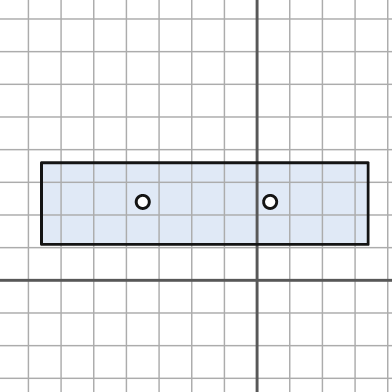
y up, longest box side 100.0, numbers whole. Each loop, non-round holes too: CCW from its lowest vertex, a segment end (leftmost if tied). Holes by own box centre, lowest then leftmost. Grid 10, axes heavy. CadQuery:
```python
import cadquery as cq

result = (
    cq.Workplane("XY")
    .moveTo(-66.0, 11.0)
    .lineTo(34.0, 11.0)
    .lineTo(34.0, 36.0)
    .lineTo(-66.0, 36.0)
    .close()
    .moveTo(-35.0, 24.0)
    .circle(2.0)
    .moveTo(4.0, 24.0)
    .circle(2.0)
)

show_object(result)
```